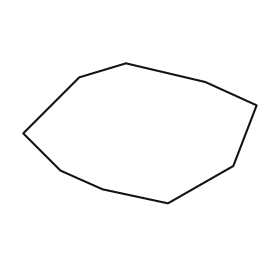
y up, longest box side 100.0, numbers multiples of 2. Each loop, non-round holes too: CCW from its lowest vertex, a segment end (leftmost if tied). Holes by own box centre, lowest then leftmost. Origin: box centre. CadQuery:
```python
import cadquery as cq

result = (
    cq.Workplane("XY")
    .moveTo(12.0, -30.0)
    .lineTo(40.0, -14.0)
    .lineTo(50.0, 12.0)
    .lineTo(28.0, 22.0)
    .lineTo(-6.0, 30.0)
    .lineTo(-26.0, 24.0)
    .lineTo(-50.0, 0.0)
    .lineTo(-34.0, -16.0)
    .lineTo(-16.0, -24.0)
    .close()
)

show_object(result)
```